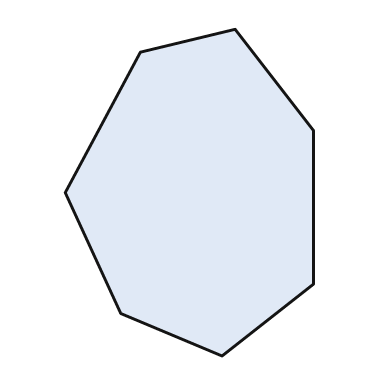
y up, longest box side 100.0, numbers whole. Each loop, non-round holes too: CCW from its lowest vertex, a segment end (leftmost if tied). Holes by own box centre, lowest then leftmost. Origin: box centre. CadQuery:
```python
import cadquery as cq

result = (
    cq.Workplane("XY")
    .moveTo(10.0, -50.0)
    .lineTo(38.0, -28.0)
    .lineTo(38.0, 19.0)
    .lineTo(14.0, 50.0)
    .lineTo(-15.0, 43.0)
    .lineTo(-38.0, 0.0)
    .lineTo(-21.0, -37.0)
    .close()
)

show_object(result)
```